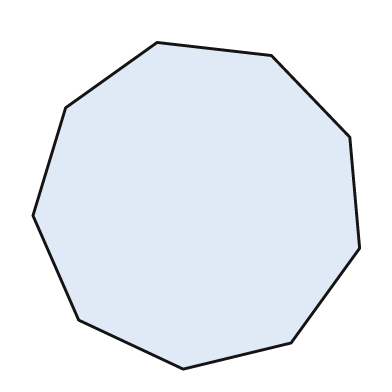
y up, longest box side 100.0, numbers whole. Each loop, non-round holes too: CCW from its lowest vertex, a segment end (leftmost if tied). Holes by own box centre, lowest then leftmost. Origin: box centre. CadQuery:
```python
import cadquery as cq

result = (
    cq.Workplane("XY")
    .moveTo(-4.0, -50.0)
    .lineTo(29.0, -42.0)
    .lineTo(50.0, -13.0)
    .lineTo(47.0, 21.0)
    .lineTo(23.0, 46.0)
    .lineTo(-12.0, 50.0)
    .lineTo(-40.0, 30.0)
    .lineTo(-50.0, -3.0)
    .lineTo(-36.0, -35.0)
    .close()
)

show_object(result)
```